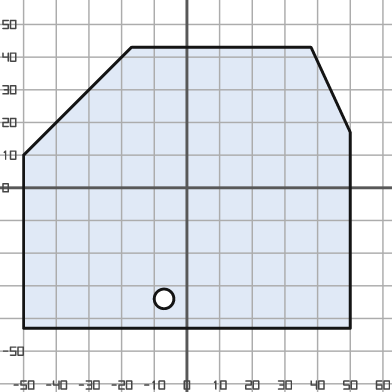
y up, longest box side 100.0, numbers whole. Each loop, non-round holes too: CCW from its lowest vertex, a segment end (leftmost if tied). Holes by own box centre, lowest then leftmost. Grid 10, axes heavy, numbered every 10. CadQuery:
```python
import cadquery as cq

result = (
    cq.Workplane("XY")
    .moveTo(-50.0, -43.0)
    .lineTo(50.0, -43.0)
    .lineTo(50.0, 17.0)
    .lineTo(38.0, 43.0)
    .lineTo(-17.0, 43.0)
    .lineTo(-50.0, 10.0)
    .close()
    .moveTo(-7.0, -34.0)
    .circle(3.0)
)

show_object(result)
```